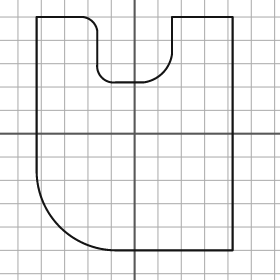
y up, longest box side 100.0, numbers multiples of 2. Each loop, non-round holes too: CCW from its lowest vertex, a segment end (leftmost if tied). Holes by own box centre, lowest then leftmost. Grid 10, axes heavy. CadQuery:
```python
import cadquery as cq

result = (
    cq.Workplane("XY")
    .moveTo(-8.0, -50.0)
    .lineTo(42.0, -50.0)
    .lineTo(42.0, 50.0)
    .lineTo(16.0, 50.0)
    .lineTo(16.0, 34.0)
    .threePointArc((12.0, 26.0), (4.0, 22.0))
    .lineTo(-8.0, 22.0)
    .threePointArc((-14.0, 24.0), (-16.0, 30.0))
    .lineTo(-16.0, 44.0)
    .threePointArc((-18.0, 48.0), (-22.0, 50.0))
    .lineTo(-42.0, 50.0)
    .lineTo(-42.0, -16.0)
    .threePointArc((-32.0, -40.0), (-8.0, -50.0))
    .close()
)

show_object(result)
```